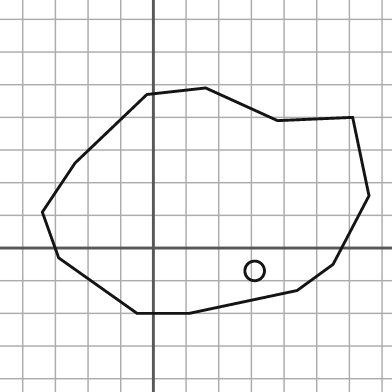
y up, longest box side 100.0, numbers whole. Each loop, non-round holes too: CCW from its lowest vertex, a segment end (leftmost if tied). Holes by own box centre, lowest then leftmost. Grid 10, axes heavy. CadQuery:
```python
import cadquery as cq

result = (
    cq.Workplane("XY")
    .moveTo(-5.0, -20.0)
    .lineTo(11.0, -20.0)
    .lineTo(44.0, -13.0)
    .lineTo(55.0, -5.0)
    .lineTo(66.0, 16.0)
    .lineTo(61.0, 40.0)
    .lineTo(38.0, 39.0)
    .lineTo(16.0, 49.0)
    .lineTo(-2.0, 47.0)
    .lineTo(-24.0, 26.0)
    .lineTo(-34.0, 11.0)
    .lineTo(-29.0, -3.0)
    .close()
    .moveTo(31.0, -7.0)
    .circle(3.0)
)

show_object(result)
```